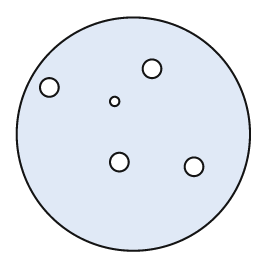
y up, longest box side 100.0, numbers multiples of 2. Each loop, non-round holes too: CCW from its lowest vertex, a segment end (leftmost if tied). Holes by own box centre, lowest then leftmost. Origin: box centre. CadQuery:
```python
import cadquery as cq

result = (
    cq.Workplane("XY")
    .moveTo(0.0, 0.0)
    .circle(50.0)
    .moveTo(26.0, -14.0)
    .circle(4.0)
    .moveTo(-6.0, -12.0)
    .circle(4.0)
    .moveTo(-8.0, 14.0)
    .circle(2.0)
    .moveTo(-36.0, 20.0)
    .circle(4.0)
    .moveTo(8.0, 28.0)
    .circle(4.0)
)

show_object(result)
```